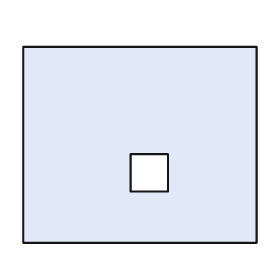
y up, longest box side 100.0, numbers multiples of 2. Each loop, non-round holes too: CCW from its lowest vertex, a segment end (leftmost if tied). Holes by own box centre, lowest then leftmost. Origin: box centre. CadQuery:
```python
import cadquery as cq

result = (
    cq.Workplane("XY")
    .moveTo(-50.0, -42.0)
    .lineTo(50.0, -42.0)
    .lineTo(50.0, 42.0)
    .lineTo(-50.0, 42.0)
    .close()
    .moveTo(-4.0, -20.0)
    .lineTo(12.0, -20.0)
    .lineTo(12.0, -4.0)
    .lineTo(-4.0, -4.0)
    .close()
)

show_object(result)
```